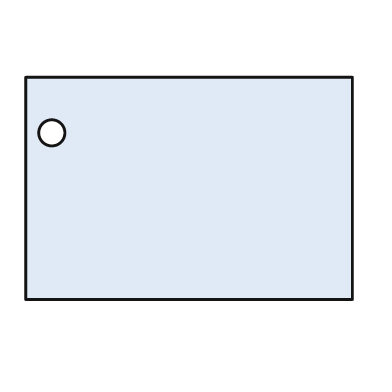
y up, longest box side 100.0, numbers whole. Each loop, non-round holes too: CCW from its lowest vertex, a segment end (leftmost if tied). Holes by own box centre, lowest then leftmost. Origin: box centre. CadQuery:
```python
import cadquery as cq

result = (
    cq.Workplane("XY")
    .moveTo(-50.0, -34.0)
    .lineTo(50.0, -34.0)
    .lineTo(50.0, 34.0)
    .lineTo(-50.0, 34.0)
    .close()
    .moveTo(-42.0, 17.0)
    .circle(4.0)
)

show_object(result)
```